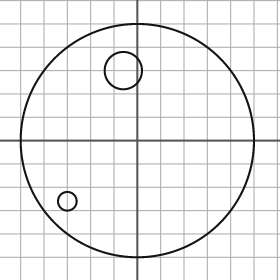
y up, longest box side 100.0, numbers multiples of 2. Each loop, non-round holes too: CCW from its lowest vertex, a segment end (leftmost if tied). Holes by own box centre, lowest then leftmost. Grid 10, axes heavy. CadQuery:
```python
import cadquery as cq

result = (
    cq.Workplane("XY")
    .moveTo(0.0, 0.0)
    .circle(50.0)
    .moveTo(-30.0, -26.0)
    .circle(4.0)
    .moveTo(-6.0, 30.0)
    .circle(8.0)
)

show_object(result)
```